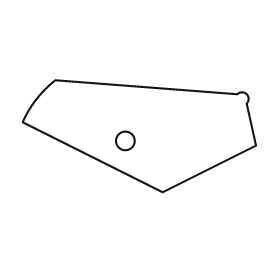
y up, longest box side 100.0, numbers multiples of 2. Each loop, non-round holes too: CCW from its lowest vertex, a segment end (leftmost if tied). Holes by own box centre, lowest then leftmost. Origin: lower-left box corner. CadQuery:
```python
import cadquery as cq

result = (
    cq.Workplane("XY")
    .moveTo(60.0, 0.0)
    .lineTo(100.0, 20.0)
    .lineTo(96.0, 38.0)
    .threePointArc((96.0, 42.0), (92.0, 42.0))
    .lineTo(14.0, 48.0)
    .threePointArc((6.0, 40.0), (0.0, 30.0))
    .close()
    .moveTo(44.0, 22.0)
    .circle(4.0)
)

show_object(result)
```